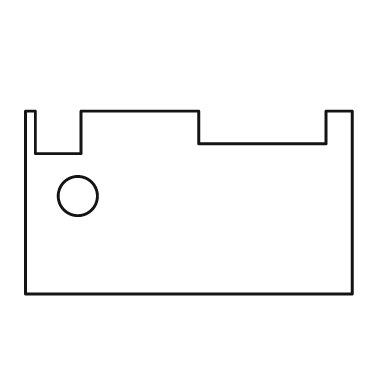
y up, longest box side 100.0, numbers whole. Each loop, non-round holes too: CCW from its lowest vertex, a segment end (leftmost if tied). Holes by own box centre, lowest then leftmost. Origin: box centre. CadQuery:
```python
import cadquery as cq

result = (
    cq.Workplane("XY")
    .moveTo(-50.0, -28.0)
    .lineTo(50.0, -28.0)
    .lineTo(50.0, 28.0)
    .lineTo(42.0, 28.0)
    .lineTo(42.0, 18.0)
    .lineTo(3.0, 18.0)
    .lineTo(3.0, 28.0)
    .lineTo(-33.0, 28.0)
    .lineTo(-33.0, 15.0)
    .lineTo(-47.0, 15.0)
    .lineTo(-47.0, 28.0)
    .lineTo(-50.0, 28.0)
    .close()
    .moveTo(-34.0, 2.0)
    .circle(6.0)
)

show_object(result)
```